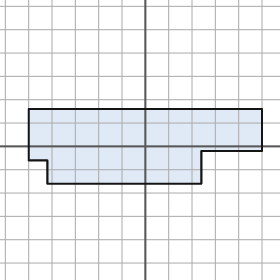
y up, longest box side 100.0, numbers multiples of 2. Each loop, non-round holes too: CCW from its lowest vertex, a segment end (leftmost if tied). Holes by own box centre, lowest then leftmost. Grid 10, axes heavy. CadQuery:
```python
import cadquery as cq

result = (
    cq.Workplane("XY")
    .moveTo(-42.0, -16.0)
    .lineTo(24.0, -16.0)
    .lineTo(24.0, -2.0)
    .lineTo(50.0, -2.0)
    .lineTo(50.0, 16.0)
    .lineTo(-50.0, 16.0)
    .lineTo(-50.0, -6.0)
    .lineTo(-42.0, -6.0)
    .close()
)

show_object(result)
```